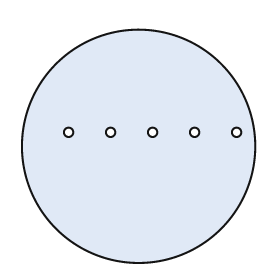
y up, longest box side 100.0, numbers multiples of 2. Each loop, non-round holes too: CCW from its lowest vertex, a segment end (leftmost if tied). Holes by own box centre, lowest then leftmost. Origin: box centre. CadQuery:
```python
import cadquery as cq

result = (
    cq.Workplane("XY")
    .moveTo(0.0, 0.0)
    .circle(50.0)
    .moveTo(-30.0, 6.0)
    .circle(2.0)
    .moveTo(-12.0, 6.0)
    .circle(2.0)
    .moveTo(6.0, 6.0)
    .circle(2.0)
    .moveTo(24.0, 6.0)
    .circle(2.0)
    .moveTo(42.0, 6.0)
    .circle(2.0)
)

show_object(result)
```